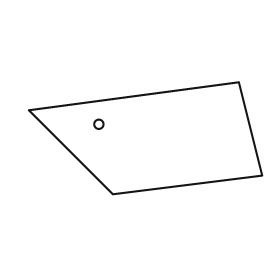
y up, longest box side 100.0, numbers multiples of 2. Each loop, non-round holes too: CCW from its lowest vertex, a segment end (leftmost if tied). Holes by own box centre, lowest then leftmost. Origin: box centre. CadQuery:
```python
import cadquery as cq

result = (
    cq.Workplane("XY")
    .moveTo(-14.0, -24.0)
    .lineTo(50.0, -16.0)
    .lineTo(40.0, 24.0)
    .lineTo(-50.0, 12.0)
    .close()
    .moveTo(-20.0, 6.0)
    .circle(2.0)
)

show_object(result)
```